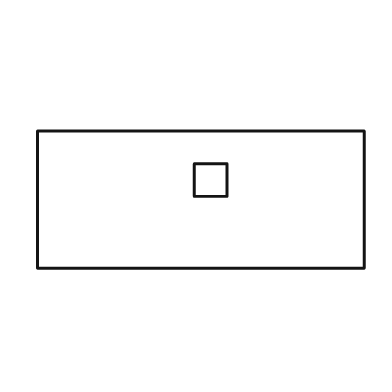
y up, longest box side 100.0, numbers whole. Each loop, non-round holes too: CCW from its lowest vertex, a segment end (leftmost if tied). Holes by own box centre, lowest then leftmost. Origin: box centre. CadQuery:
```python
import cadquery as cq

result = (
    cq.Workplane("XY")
    .moveTo(-50.0, -21.0)
    .lineTo(50.0, -21.0)
    .lineTo(50.0, 21.0)
    .lineTo(-50.0, 21.0)
    .close()
    .moveTo(-2.0, 1.0)
    .lineTo(8.0, 1.0)
    .lineTo(8.0, 11.0)
    .lineTo(-2.0, 11.0)
    .close()
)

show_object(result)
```